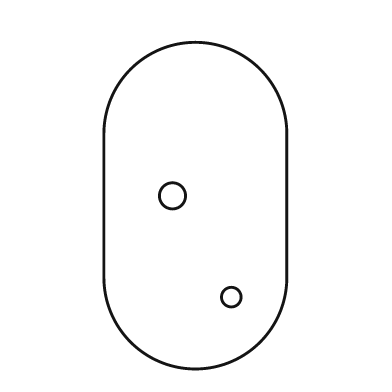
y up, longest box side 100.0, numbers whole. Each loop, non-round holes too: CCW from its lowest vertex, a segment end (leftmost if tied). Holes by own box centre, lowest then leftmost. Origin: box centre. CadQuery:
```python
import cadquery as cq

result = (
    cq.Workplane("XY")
    .moveTo(-28.0, -22.0)
    .threePointArc((0.0, -50.0), (28.0, -22.0))
    .lineTo(28.0, 22.0)
    .threePointArc((0.0, 50.0), (-28.0, 22.0))
    .close()
    .moveTo(11.0, -28.0)
    .circle(3.0)
    .moveTo(-7.0, 3.0)
    .circle(4.0)
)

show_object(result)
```